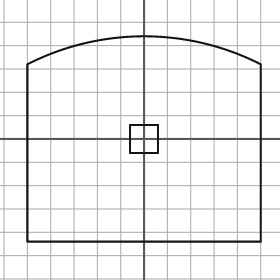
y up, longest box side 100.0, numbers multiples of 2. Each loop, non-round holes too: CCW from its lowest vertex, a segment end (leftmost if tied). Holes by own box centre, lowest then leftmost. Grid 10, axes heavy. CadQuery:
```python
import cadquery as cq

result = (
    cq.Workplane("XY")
    .moveTo(-50.0, -44.0)
    .lineTo(50.0, -44.0)
    .lineTo(50.0, 32.0)
    .threePointArc((0.0, 44.0), (-50.0, 32.0))
    .close()
    .moveTo(-6.0, -6.0)
    .lineTo(6.0, -6.0)
    .lineTo(6.0, 6.0)
    .lineTo(-6.0, 6.0)
    .close()
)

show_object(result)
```